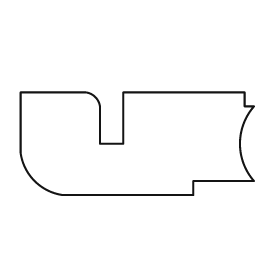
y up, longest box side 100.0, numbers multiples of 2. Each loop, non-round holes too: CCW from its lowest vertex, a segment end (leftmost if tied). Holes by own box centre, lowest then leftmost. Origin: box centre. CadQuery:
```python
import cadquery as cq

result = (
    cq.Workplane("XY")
    .moveTo(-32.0, -22.0)
    .lineTo(24.0, -22.0)
    .lineTo(24.0, -16.0)
    .lineTo(50.0, -16.0)
    .threePointArc((44.0, 0.0), (50.0, 16.0))
    .lineTo(46.0, 16.0)
    .lineTo(46.0, 22.0)
    .lineTo(-6.0, 22.0)
    .lineTo(-6.0, 0.0)
    .lineTo(-16.0, 0.0)
    .lineTo(-16.0, 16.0)
    .threePointArc((-18.0, 20.0), (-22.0, 22.0))
    .lineTo(-50.0, 22.0)
    .lineTo(-50.0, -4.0)
    .threePointArc((-44.0, -16.0), (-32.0, -22.0))
    .close()
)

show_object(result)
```